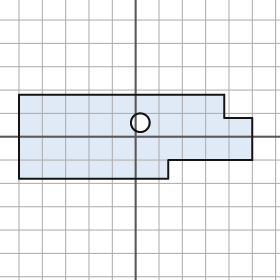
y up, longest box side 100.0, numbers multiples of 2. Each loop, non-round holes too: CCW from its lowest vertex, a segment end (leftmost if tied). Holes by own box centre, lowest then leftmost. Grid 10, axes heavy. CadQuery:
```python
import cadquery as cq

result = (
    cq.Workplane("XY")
    .moveTo(-50.0, -18.0)
    .lineTo(14.0, -18.0)
    .lineTo(14.0, -10.0)
    .lineTo(50.0, -10.0)
    .lineTo(50.0, 8.0)
    .lineTo(38.0, 8.0)
    .lineTo(38.0, 18.0)
    .lineTo(-50.0, 18.0)
    .close()
    .moveTo(2.0, 6.0)
    .circle(4.0)
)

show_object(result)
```